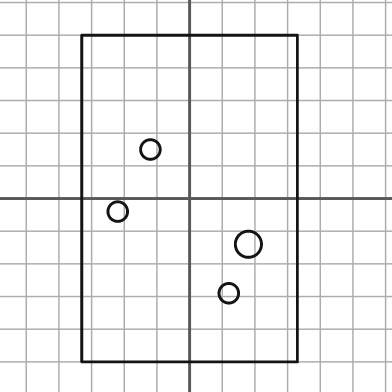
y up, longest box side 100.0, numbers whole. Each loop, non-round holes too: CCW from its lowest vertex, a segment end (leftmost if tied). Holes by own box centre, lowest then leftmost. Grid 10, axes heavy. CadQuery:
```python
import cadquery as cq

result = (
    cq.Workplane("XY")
    .moveTo(-33.0, -50.0)
    .lineTo(33.0, -50.0)
    .lineTo(33.0, 50.0)
    .lineTo(-33.0, 50.0)
    .close()
    .moveTo(12.0, -29.0)
    .circle(3.0)
    .moveTo(18.0, -14.0)
    .circle(4.0)
    .moveTo(-22.0, -4.0)
    .circle(3.0)
    .moveTo(-12.0, 15.0)
    .circle(3.0)
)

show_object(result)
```